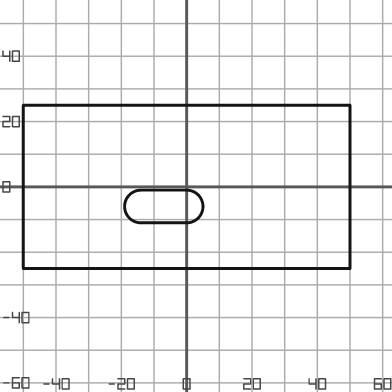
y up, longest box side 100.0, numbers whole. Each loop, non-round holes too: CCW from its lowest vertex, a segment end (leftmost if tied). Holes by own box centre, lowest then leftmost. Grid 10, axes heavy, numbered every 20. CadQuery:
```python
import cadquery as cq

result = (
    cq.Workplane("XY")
    .moveTo(-50.0, -25.0)
    .lineTo(50.0, -25.0)
    .lineTo(50.0, 25.0)
    .lineTo(-50.0, 25.0)
    .close()
    .moveTo(-14.0, -11.0)
    .lineTo(0.0, -11.0)
    .threePointArc((5.0, -6.0), (0.0, -1.0))
    .lineTo(-14.0, -1.0)
    .threePointArc((-19.0, -6.0), (-14.0, -11.0))
    .close()
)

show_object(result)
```